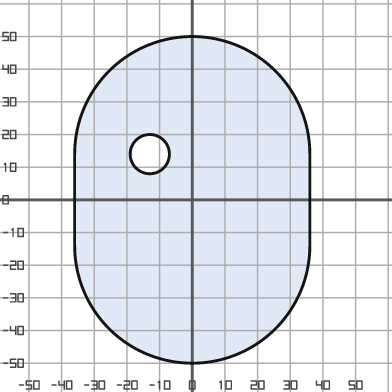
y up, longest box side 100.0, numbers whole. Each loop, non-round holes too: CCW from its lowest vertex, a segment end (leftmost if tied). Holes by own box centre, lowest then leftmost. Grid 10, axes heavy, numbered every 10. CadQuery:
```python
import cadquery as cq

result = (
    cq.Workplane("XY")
    .moveTo(-36.0, -14.0)
    .threePointArc((0.0, -50.0), (36.0, -14.0))
    .lineTo(36.0, 14.0)
    .threePointArc((0.0, 50.0), (-36.0, 14.0))
    .close()
    .moveTo(-13.0, 14.0)
    .circle(6.0)
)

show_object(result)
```